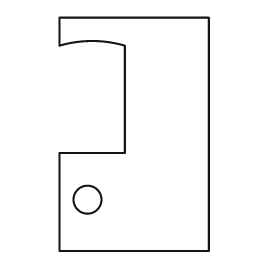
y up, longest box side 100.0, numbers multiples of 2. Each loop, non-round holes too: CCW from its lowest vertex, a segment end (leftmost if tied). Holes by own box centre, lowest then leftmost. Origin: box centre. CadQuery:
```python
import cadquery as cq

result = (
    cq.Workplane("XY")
    .moveTo(-32.0, -50.0)
    .lineTo(32.0, -50.0)
    .lineTo(32.0, 50.0)
    .lineTo(-32.0, 50.0)
    .lineTo(-32.0, 38.0)
    .threePointArc((-18.0, 40.0), (-4.0, 38.0))
    .lineTo(-4.0, -8.0)
    .lineTo(-32.0, -8.0)
    .close()
    .moveTo(-20.0, -28.0)
    .circle(6.0)
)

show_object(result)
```